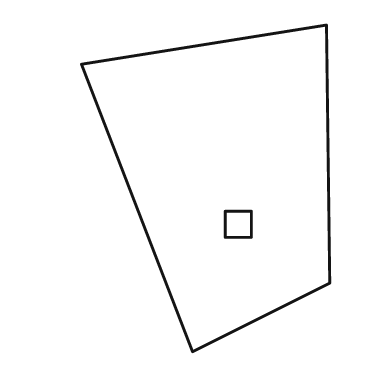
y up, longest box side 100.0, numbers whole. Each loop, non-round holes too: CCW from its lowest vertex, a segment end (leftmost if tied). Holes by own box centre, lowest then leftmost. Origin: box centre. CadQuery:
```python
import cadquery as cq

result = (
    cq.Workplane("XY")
    .moveTo(-4.0, -50.0)
    .lineTo(38.0, -29.0)
    .lineTo(37.0, 50.0)
    .lineTo(-38.0, 38.0)
    .close()
    .moveTo(6.0, -15.0)
    .lineTo(14.0, -15.0)
    .lineTo(14.0, -7.0)
    .lineTo(6.0, -7.0)
    .close()
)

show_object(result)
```